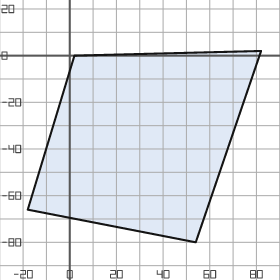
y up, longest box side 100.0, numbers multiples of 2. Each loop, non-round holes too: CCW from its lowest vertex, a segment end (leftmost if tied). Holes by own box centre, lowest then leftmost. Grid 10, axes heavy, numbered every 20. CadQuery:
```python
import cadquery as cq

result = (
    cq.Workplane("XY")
    .moveTo(54.0, -80.0)
    .lineTo(82.0, 2.0)
    .lineTo(2.0, 0.0)
    .lineTo(-18.0, -66.0)
    .close()
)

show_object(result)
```